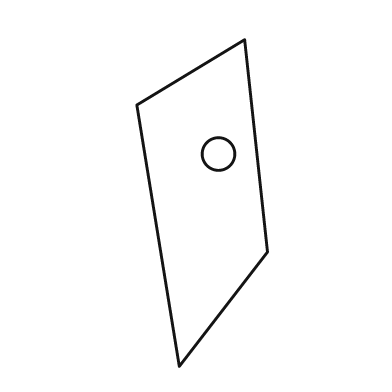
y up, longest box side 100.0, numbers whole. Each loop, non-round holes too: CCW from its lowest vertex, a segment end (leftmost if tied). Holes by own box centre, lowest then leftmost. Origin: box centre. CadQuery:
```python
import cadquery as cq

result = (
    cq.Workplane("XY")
    .moveTo(-7.0, -50.0)
    .lineTo(20.0, -15.0)
    .lineTo(13.0, 50.0)
    .lineTo(-20.0, 30.0)
    .close()
    .moveTo(5.0, 15.0)
    .circle(5.0)
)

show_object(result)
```